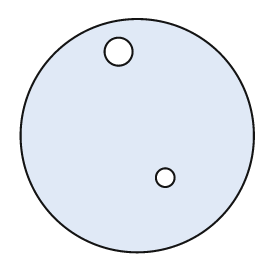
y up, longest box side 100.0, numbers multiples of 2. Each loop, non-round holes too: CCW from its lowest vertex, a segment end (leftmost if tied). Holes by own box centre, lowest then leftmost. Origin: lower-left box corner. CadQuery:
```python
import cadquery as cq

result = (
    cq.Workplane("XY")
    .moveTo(50.0, 50.0)
    .circle(50.0)
    .moveTo(62.0, 32.0)
    .circle(4.0)
    .moveTo(42.0, 86.0)
    .circle(6.0)
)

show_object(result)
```